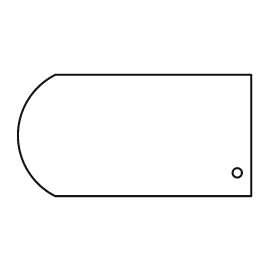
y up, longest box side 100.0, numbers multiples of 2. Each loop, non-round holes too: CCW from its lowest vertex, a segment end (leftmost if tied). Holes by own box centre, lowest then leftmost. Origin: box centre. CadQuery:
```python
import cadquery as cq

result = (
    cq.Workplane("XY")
    .moveTo(-34.0, -26.0)
    .lineTo(50.0, -26.0)
    .lineTo(50.0, 26.0)
    .lineTo(-34.0, 26.0)
    .threePointArc((-50.0, 0.0), (-34.0, -26.0))
    .close()
    .moveTo(44.0, -16.0)
    .circle(2.0)
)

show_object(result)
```